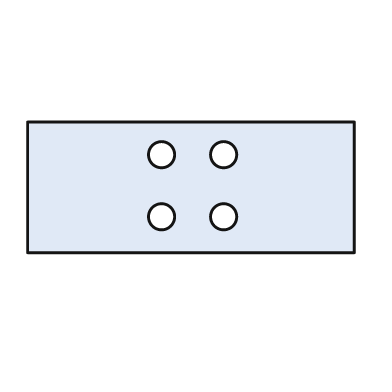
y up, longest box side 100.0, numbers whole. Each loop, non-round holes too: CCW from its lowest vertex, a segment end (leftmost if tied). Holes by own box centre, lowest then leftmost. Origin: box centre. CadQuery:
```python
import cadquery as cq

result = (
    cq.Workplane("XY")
    .moveTo(-50.0, -20.0)
    .lineTo(50.0, -20.0)
    .lineTo(50.0, 20.0)
    .lineTo(-50.0, 20.0)
    .close()
    .moveTo(-9.0, -9.0)
    .circle(4.0)
    .moveTo(10.0, -9.0)
    .circle(4.0)
    .moveTo(-9.0, 10.0)
    .circle(4.0)
    .moveTo(10.0, 10.0)
    .circle(4.0)
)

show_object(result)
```